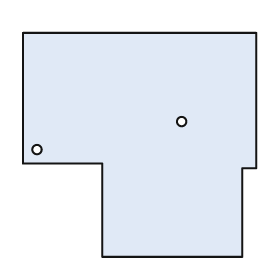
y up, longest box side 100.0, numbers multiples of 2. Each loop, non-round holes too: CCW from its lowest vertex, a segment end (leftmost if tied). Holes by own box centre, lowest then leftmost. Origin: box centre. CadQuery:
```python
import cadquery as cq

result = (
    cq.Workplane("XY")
    .moveTo(-16.0, -48.0)
    .lineTo(44.0, -48.0)
    .lineTo(44.0, -10.0)
    .lineTo(50.0, -10.0)
    .lineTo(50.0, 48.0)
    .lineTo(-50.0, 48.0)
    .lineTo(-50.0, -8.0)
    .lineTo(-16.0, -8.0)
    .close()
    .moveTo(-44.0, -2.0)
    .circle(2.0)
    .moveTo(18.0, 10.0)
    .circle(2.0)
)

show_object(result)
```